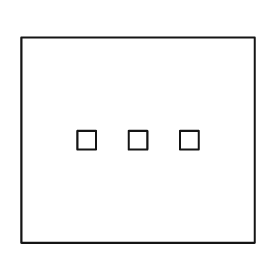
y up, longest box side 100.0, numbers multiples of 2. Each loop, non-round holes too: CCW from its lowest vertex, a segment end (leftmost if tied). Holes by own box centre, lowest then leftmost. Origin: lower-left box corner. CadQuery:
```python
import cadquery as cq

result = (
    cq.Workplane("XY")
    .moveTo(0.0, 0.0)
    .lineTo(100.0, 0.0)
    .lineTo(100.0, 88.0)
    .lineTo(0.0, 88.0)
    .close()
    .moveTo(24.0, 40.0)
    .lineTo(32.0, 40.0)
    .lineTo(32.0, 48.0)
    .lineTo(24.0, 48.0)
    .close()
    .moveTo(46.0, 40.0)
    .lineTo(54.0, 40.0)
    .lineTo(54.0, 48.0)
    .lineTo(46.0, 48.0)
    .close()
    .moveTo(68.0, 40.0)
    .lineTo(76.0, 40.0)
    .lineTo(76.0, 48.0)
    .lineTo(68.0, 48.0)
    .close()
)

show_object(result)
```